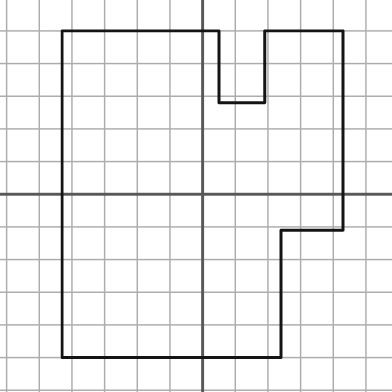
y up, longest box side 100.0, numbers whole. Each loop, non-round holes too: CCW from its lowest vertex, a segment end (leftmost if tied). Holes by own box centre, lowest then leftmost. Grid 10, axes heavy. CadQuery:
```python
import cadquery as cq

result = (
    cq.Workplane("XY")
    .moveTo(-43.0, -50.0)
    .lineTo(24.0, -50.0)
    .lineTo(24.0, -11.0)
    .lineTo(43.0, -11.0)
    .lineTo(43.0, 50.0)
    .lineTo(19.0, 50.0)
    .lineTo(19.0, 28.0)
    .lineTo(5.0, 28.0)
    .lineTo(5.0, 50.0)
    .lineTo(-43.0, 50.0)
    .close()
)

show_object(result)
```